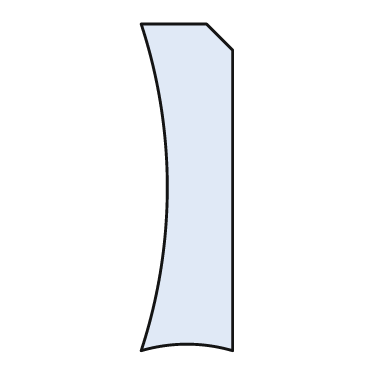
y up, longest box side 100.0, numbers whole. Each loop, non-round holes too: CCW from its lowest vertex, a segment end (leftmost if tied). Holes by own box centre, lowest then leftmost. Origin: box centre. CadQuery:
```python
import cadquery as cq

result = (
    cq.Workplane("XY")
    .moveTo(-14.0, -50.0)
    .threePointArc((0.0, -48.0), (14.0, -50.0))
    .lineTo(14.0, 42.0)
    .lineTo(6.0, 50.0)
    .lineTo(-14.0, 50.0)
    .threePointArc((-6.0, 0.0), (-14.0, -50.0))
    .close()
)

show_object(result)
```